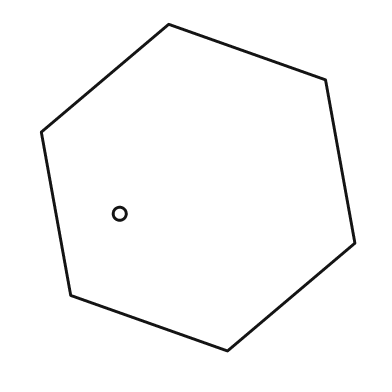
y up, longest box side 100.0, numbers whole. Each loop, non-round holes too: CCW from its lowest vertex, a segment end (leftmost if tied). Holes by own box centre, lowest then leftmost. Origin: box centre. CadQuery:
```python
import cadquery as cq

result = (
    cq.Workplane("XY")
    .moveTo(9.0, -50.0)
    .lineTo(48.0, -17.0)
    .lineTo(39.0, 33.0)
    .lineTo(-9.0, 50.0)
    .lineTo(-48.0, 17.0)
    .lineTo(-39.0, -33.0)
    .close()
    .moveTo(-24.0, -8.0)
    .circle(2.0)
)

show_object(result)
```